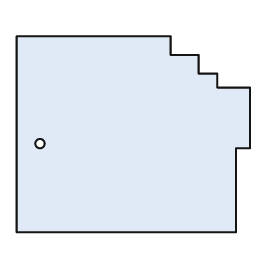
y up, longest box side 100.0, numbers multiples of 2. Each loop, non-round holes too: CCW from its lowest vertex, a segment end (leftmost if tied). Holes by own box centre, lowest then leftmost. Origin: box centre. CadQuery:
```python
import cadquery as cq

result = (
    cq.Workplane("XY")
    .moveTo(-50.0, -42.0)
    .lineTo(44.0, -42.0)
    .lineTo(44.0, -6.0)
    .lineTo(50.0, -6.0)
    .lineTo(50.0, 20.0)
    .lineTo(36.0, 20.0)
    .lineTo(36.0, 26.0)
    .lineTo(28.0, 26.0)
    .lineTo(28.0, 34.0)
    .lineTo(16.0, 34.0)
    .lineTo(16.0, 42.0)
    .lineTo(-50.0, 42.0)
    .close()
    .moveTo(-40.0, -4.0)
    .circle(2.0)
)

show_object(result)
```